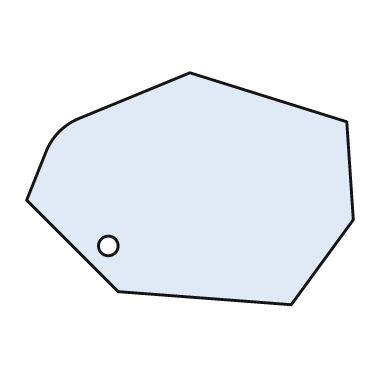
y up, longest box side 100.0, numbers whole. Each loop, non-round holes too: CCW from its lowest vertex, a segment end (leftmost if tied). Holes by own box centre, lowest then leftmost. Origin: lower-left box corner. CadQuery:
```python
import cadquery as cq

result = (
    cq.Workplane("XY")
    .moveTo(81.0, 0.0)
    .lineTo(100.0, 26.0)
    .lineTo(98.0, 56.0)
    .lineTo(50.0, 71.0)
    .lineTo(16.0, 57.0)
    .threePointArc((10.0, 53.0), (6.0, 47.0))
    .lineTo(0.0, 32.0)
    .lineTo(28.0, 4.0)
    .close()
    .moveTo(25.0, 18.0)
    .circle(3.0)
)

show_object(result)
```